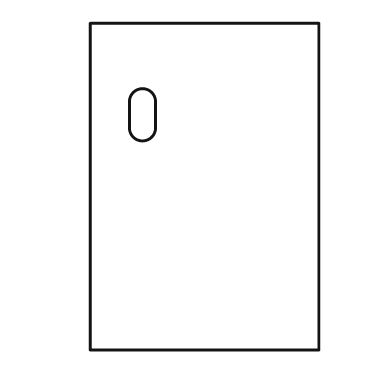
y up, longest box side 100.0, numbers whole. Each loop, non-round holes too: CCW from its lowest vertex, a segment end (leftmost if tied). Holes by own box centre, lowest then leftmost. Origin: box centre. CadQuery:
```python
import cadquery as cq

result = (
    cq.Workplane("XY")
    .moveTo(-35.0, -50.0)
    .lineTo(35.0, -50.0)
    .lineTo(35.0, 50.0)
    .lineTo(-35.0, 50.0)
    .close()
    .moveTo(-23.0, 18.0)
    .threePointArc((-19.0, 14.0), (-15.0, 18.0))
    .lineTo(-15.0, 26.0)
    .threePointArc((-19.0, 30.0), (-23.0, 26.0))
    .close()
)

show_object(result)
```